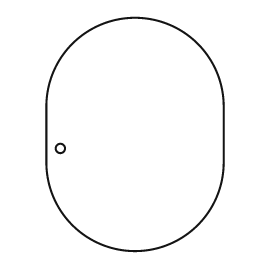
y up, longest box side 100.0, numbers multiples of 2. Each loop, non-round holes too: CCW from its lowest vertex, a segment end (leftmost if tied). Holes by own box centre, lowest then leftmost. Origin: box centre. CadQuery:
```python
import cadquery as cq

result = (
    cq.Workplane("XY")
    .moveTo(-38.0, -12.0)
    .threePointArc((0.0, -50.0), (38.0, -12.0))
    .lineTo(38.0, 12.0)
    .threePointArc((0.0, 50.0), (-38.0, 12.0))
    .close()
    .moveTo(-32.0, -6.0)
    .circle(2.0)
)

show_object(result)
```